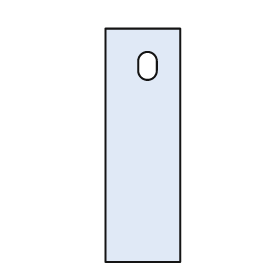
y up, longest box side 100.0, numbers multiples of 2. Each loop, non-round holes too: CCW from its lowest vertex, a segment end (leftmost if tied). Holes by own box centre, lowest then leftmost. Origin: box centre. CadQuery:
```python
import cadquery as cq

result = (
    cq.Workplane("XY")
    .moveTo(-16.0, -50.0)
    .lineTo(16.0, -50.0)
    .lineTo(16.0, 50.0)
    .lineTo(-16.0, 50.0)
    .close()
    .moveTo(-2.0, 32.0)
    .threePointArc((2.0, 28.0), (6.0, 32.0))
    .lineTo(6.0, 36.0)
    .threePointArc((2.0, 40.0), (-2.0, 36.0))
    .close()
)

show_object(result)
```